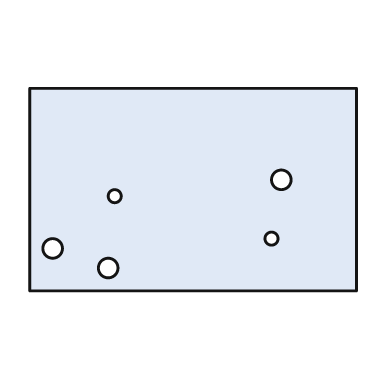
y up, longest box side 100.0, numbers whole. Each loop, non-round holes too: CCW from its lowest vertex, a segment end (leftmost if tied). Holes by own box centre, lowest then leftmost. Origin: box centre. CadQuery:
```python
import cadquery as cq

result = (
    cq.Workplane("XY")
    .moveTo(-50.0, -31.0)
    .lineTo(50.0, -31.0)
    .lineTo(50.0, 31.0)
    .lineTo(-50.0, 31.0)
    .close()
    .moveTo(-26.0, -24.0)
    .circle(3.0)
    .moveTo(-43.0, -18.0)
    .circle(3.0)
    .moveTo(24.0, -15.0)
    .circle(2.0)
    .moveTo(-24.0, -2.0)
    .circle(2.0)
    .moveTo(27.0, 3.0)
    .circle(3.0)
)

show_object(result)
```